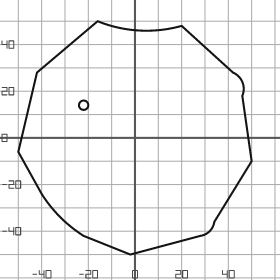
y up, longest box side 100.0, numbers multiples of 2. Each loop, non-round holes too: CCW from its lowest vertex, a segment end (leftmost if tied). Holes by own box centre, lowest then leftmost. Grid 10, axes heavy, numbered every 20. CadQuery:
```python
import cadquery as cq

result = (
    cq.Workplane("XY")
    .moveTo(-2.0, -50.0)
    .lineTo(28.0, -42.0)
    .threePointArc((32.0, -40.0), (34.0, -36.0))
    .lineTo(50.0, -10.0)
    .lineTo(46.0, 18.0)
    .threePointArc((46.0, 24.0), (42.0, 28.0))
    .lineTo(20.0, 48.0)
    .threePointArc((2.0, 46.0), (-16.0, 50.0))
    .lineTo(-42.0, 28.0)
    .lineTo(-50.0, -6.0)
    .lineTo(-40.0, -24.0)
    .threePointArc((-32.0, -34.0), (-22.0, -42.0))
    .close()
    .moveTo(-22.0, 14.0)
    .circle(2.0)
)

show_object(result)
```